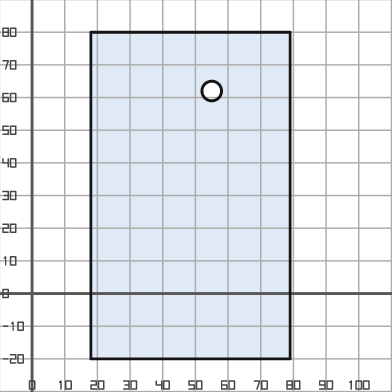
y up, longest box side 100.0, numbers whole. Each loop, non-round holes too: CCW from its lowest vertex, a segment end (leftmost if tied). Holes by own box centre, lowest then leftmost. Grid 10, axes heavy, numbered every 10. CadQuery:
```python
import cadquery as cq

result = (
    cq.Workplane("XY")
    .moveTo(18.0, -20.0)
    .lineTo(79.0, -20.0)
    .lineTo(79.0, 80.0)
    .lineTo(18.0, 80.0)
    .close()
    .moveTo(55.0, 62.0)
    .circle(3.0)
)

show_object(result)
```